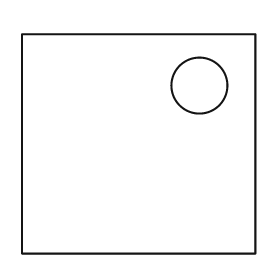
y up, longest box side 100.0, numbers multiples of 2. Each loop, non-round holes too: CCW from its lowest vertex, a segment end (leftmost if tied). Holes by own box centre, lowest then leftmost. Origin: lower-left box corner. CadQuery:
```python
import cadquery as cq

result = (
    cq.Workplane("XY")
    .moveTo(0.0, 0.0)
    .lineTo(100.0, 0.0)
    .lineTo(100.0, 94.0)
    .lineTo(0.0, 94.0)
    .close()
    .moveTo(76.0, 72.0)
    .circle(12.0)
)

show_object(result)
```